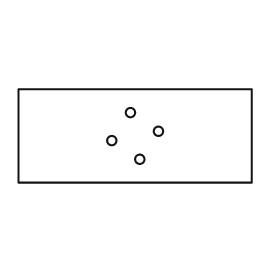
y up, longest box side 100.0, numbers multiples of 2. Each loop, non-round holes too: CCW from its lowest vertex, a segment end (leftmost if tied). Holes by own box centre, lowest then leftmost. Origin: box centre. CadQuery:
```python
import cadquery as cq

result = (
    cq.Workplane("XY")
    .moveTo(-50.0, -20.0)
    .lineTo(50.0, -20.0)
    .lineTo(50.0, 20.0)
    .lineTo(-50.0, 20.0)
    .close()
    .moveTo(2.0, -10.0)
    .circle(2.0)
    .moveTo(-10.0, -2.0)
    .circle(2.0)
    .moveTo(10.0, 2.0)
    .circle(2.0)
    .moveTo(-2.0, 10.0)
    .circle(2.0)
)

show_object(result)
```